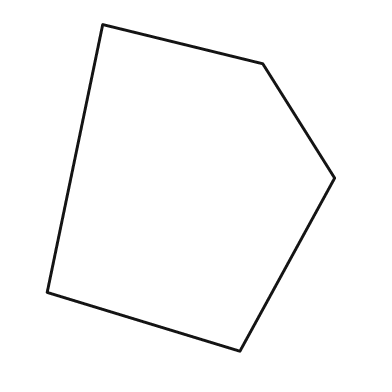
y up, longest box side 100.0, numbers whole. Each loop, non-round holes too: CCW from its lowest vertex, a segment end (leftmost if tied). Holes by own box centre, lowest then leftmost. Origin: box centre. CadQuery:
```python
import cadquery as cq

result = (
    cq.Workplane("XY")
    .moveTo(15.0, -50.0)
    .lineTo(44.0, 3.0)
    .lineTo(22.0, 38.0)
    .lineTo(-27.0, 50.0)
    .lineTo(-44.0, -32.0)
    .close()
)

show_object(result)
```